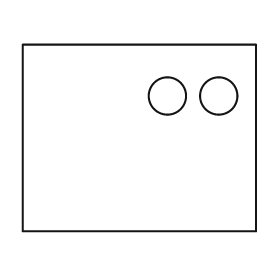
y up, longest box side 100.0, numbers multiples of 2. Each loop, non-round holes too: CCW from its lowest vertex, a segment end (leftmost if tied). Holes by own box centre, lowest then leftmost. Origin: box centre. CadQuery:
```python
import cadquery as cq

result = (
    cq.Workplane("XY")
    .moveTo(-50.0, -40.0)
    .lineTo(50.0, -40.0)
    .lineTo(50.0, 40.0)
    .lineTo(-50.0, 40.0)
    .close()
    .moveTo(12.0, 18.0)
    .circle(8.0)
    .moveTo(34.0, 18.0)
    .circle(8.0)
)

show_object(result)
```